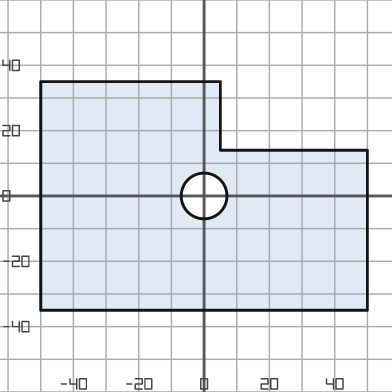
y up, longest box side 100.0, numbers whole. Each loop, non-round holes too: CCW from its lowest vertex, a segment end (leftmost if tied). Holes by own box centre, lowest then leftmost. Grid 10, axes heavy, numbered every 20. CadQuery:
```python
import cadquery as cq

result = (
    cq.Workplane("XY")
    .moveTo(-50.0, -35.0)
    .lineTo(50.0, -35.0)
    .lineTo(50.0, 14.0)
    .lineTo(5.0, 14.0)
    .lineTo(5.0, 35.0)
    .lineTo(-50.0, 35.0)
    .close()
    .moveTo(0.0, 0.0)
    .circle(7.0)
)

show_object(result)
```